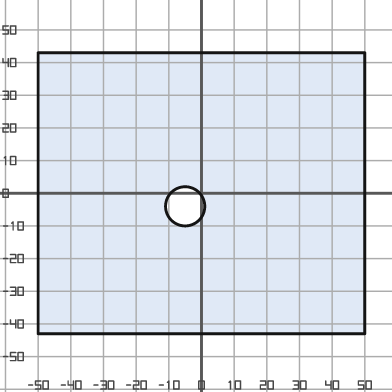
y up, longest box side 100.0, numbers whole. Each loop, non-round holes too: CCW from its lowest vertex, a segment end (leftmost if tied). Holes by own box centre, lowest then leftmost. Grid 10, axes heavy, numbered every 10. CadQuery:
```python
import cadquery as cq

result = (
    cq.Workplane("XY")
    .moveTo(-50.0, -43.0)
    .lineTo(50.0, -43.0)
    .lineTo(50.0, 43.0)
    .lineTo(-50.0, 43.0)
    .close()
    .moveTo(-5.0, -4.0)
    .circle(6.0)
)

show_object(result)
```